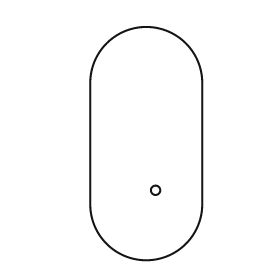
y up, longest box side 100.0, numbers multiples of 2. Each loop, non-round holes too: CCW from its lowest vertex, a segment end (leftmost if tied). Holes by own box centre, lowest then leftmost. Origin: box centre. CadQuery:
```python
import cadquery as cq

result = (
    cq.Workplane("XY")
    .moveTo(-24.0, -26.0)
    .threePointArc((0.0, -50.0), (24.0, -26.0))
    .lineTo(24.0, 26.0)
    .threePointArc((0.0, 50.0), (-24.0, 26.0))
    .close()
    .moveTo(4.0, -20.0)
    .circle(2.0)
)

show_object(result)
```